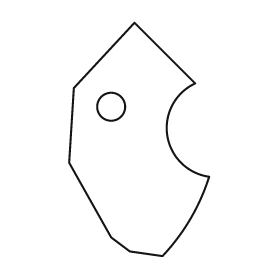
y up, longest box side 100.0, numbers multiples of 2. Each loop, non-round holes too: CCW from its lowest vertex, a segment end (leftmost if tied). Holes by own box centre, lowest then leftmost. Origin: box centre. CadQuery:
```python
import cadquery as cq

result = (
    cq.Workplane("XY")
    .moveTo(10.0, -50.0)
    .threePointArc((22.0, -34.0), (30.0, -16.0))
    .threePointArc((12.0, 2.0), (24.0, 24.0))
    .lineTo(-2.0, 50.0)
    .lineTo(-28.0, 22.0)
    .lineTo(-30.0, -10.0)
    .lineTo(-12.0, -42.0)
    .lineTo(-4.0, -48.0)
    .close()
    .moveTo(-12.0, 14.0)
    .circle(6.0)
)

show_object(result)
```